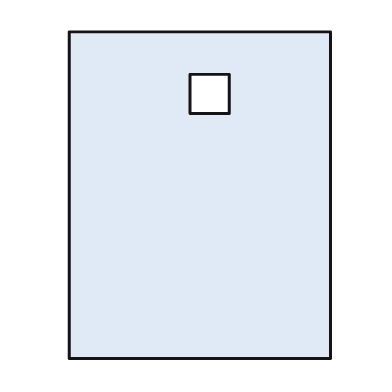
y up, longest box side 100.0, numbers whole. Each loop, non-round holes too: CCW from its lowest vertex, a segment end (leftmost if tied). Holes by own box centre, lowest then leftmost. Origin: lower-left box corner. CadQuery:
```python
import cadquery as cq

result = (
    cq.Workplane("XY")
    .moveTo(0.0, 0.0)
    .lineTo(80.0, 0.0)
    .lineTo(80.0, 100.0)
    .lineTo(0.0, 100.0)
    .close()
    .moveTo(37.0, 75.0)
    .lineTo(49.0, 75.0)
    .lineTo(49.0, 87.0)
    .lineTo(37.0, 87.0)
    .close()
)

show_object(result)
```